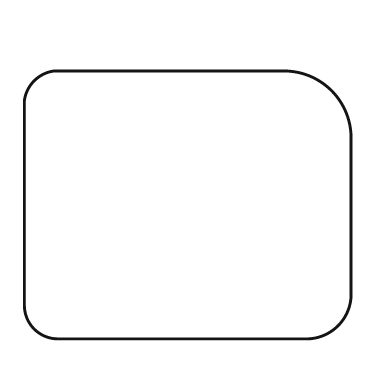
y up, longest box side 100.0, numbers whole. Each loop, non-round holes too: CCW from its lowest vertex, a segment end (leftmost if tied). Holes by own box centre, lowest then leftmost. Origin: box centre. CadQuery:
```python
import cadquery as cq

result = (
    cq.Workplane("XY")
    .moveTo(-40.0, -41.0)
    .lineTo(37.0, -41.0)
    .threePointArc((46.0, -37.0), (50.0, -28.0))
    .lineTo(50.0, 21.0)
    .threePointArc((44.0, 35.0), (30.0, 41.0))
    .lineTo(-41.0, 41.0)
    .threePointArc((-47.0, 38.0), (-50.0, 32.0))
    .lineTo(-50.0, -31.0)
    .threePointArc((-47.0, -38.0), (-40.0, -41.0))
    .close()
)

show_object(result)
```